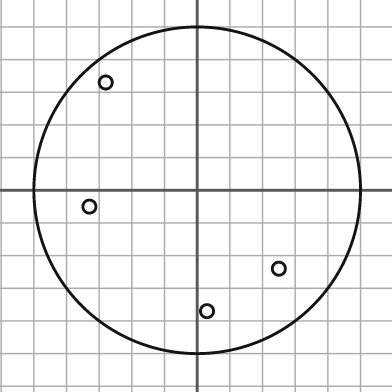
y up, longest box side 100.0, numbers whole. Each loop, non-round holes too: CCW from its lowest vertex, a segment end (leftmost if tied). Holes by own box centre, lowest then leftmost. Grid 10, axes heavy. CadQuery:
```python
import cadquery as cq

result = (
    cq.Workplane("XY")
    .moveTo(0.0, 0.0)
    .circle(50.0)
    .moveTo(3.0, -37.0)
    .circle(2.0)
    .moveTo(25.0, -24.0)
    .circle(2.0)
    .moveTo(-33.0, -5.0)
    .circle(2.0)
    .moveTo(-28.0, 33.0)
    .circle(2.0)
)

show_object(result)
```